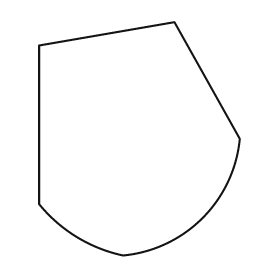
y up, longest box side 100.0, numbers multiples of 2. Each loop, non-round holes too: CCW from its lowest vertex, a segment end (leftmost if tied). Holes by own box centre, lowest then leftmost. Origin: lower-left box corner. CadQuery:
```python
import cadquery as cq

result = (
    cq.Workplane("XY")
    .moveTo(36.0, 0.0)
    .threePointArc((70.0, 16.0), (86.0, 50.0))
    .lineTo(58.0, 100.0)
    .lineTo(0.0, 90.0)
    .lineTo(0.0, 22.0)
    .threePointArc((16.0, 8.0), (36.0, 0.0))
    .close()
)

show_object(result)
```